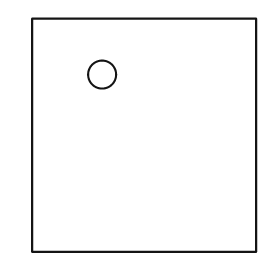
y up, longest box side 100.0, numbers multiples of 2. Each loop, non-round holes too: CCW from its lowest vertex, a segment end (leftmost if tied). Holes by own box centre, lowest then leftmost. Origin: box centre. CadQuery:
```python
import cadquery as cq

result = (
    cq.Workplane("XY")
    .moveTo(-48.0, -50.0)
    .lineTo(48.0, -50.0)
    .lineTo(48.0, 50.0)
    .lineTo(-48.0, 50.0)
    .close()
    .moveTo(-18.0, 26.0)
    .circle(6.0)
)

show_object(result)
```